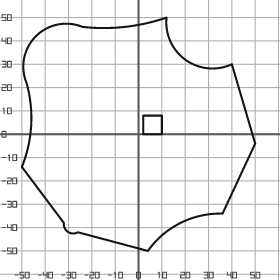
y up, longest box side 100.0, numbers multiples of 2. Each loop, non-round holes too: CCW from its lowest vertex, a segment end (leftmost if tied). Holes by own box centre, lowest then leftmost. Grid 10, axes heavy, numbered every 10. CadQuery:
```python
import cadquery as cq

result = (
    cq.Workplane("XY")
    .moveTo(4.0, -50.0)
    .threePointArc((18.0, -38.0), (36.0, -34.0))
    .lineTo(50.0, -4.0)
    .lineTo(40.0, 30.0)
    .threePointArc((20.0, 32.0), (12.0, 50.0))
    .threePointArc((-6.0, 46.0), (-24.0, 46.0))
    .threePointArc((-44.0, 42.0), (-48.0, 22.0))
    .threePointArc((-46.0, 4.0), (-50.0, -14.0))
    .lineTo(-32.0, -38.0)
    .threePointArc((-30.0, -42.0), (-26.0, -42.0))
    .close()
    .moveTo(2.0, 0.0)
    .lineTo(10.0, 0.0)
    .lineTo(10.0, 8.0)
    .lineTo(2.0, 8.0)
    .close()
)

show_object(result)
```